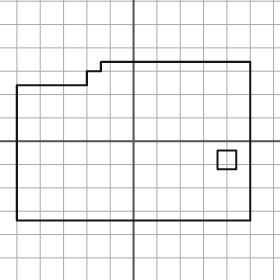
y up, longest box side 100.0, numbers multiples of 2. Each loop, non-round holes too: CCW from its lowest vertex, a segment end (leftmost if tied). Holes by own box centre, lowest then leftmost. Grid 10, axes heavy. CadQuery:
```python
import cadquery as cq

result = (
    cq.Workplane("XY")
    .moveTo(-50.0, -34.0)
    .lineTo(50.0, -34.0)
    .lineTo(50.0, 34.0)
    .lineTo(-14.0, 34.0)
    .lineTo(-14.0, 30.0)
    .lineTo(-20.0, 30.0)
    .lineTo(-20.0, 24.0)
    .lineTo(-50.0, 24.0)
    .close()
    .moveTo(36.0, -12.0)
    .lineTo(44.0, -12.0)
    .lineTo(44.0, -4.0)
    .lineTo(36.0, -4.0)
    .close()
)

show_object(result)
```